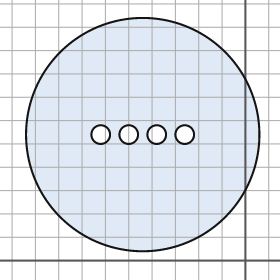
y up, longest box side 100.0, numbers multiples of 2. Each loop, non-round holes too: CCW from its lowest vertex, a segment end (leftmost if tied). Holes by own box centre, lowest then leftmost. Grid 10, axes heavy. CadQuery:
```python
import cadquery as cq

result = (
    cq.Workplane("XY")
    .moveTo(-44.0, 54.0)
    .circle(50.0)
    .moveTo(-62.0, 54.0)
    .circle(4.0)
    .moveTo(-50.0, 54.0)
    .circle(4.0)
    .moveTo(-38.0, 54.0)
    .circle(4.0)
    .moveTo(-26.0, 54.0)
    .circle(4.0)
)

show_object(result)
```